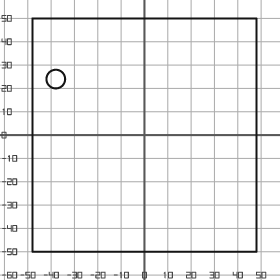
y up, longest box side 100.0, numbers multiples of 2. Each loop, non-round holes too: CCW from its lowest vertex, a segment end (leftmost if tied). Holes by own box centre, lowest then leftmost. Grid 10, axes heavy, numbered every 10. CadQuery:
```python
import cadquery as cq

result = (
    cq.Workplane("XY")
    .moveTo(-48.0, -50.0)
    .lineTo(48.0, -50.0)
    .lineTo(48.0, 50.0)
    .lineTo(-48.0, 50.0)
    .close()
    .moveTo(-38.0, 24.0)
    .circle(4.0)
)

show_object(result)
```